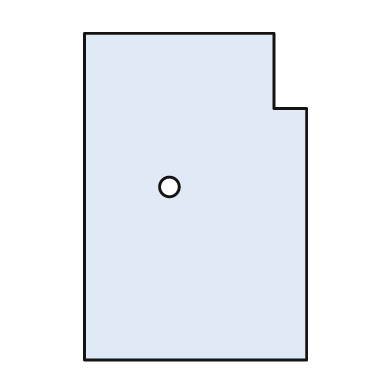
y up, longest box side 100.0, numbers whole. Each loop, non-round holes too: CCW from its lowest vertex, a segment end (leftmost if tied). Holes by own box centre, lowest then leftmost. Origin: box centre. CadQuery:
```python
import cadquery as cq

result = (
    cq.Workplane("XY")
    .moveTo(-34.0, -50.0)
    .lineTo(34.0, -50.0)
    .lineTo(34.0, 27.0)
    .lineTo(24.0, 27.0)
    .lineTo(24.0, 50.0)
    .lineTo(-34.0, 50.0)
    .close()
    .moveTo(-8.0, 3.0)
    .circle(3.0)
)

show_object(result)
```